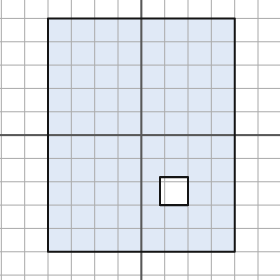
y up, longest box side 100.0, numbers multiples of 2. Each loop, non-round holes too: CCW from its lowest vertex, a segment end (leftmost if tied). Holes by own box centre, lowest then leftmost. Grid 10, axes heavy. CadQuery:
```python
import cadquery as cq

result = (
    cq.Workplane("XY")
    .moveTo(-40.0, -50.0)
    .lineTo(40.0, -50.0)
    .lineTo(40.0, 50.0)
    .lineTo(-40.0, 50.0)
    .close()
    .moveTo(8.0, -30.0)
    .lineTo(20.0, -30.0)
    .lineTo(20.0, -18.0)
    .lineTo(8.0, -18.0)
    .close()
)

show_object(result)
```